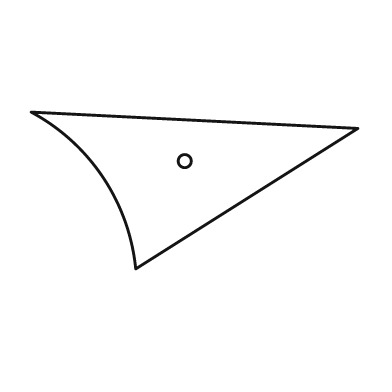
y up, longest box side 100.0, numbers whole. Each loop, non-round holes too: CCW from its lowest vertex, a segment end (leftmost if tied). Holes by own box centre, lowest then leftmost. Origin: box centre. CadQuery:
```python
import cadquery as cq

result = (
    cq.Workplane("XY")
    .moveTo(-18.0, -24.0)
    .lineTo(50.0, 19.0)
    .lineTo(-50.0, 24.0)
    .threePointArc((-28.0, 4.0), (-18.0, -24.0))
    .close()
    .moveTo(-3.0, 9.0)
    .circle(2.0)
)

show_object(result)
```